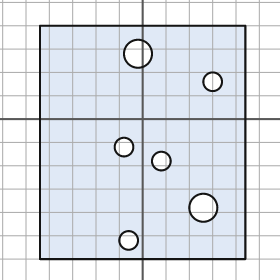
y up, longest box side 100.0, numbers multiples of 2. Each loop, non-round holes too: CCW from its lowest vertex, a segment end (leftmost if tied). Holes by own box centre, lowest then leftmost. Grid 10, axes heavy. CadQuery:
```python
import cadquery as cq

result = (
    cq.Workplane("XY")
    .moveTo(-44.0, -60.0)
    .lineTo(44.0, -60.0)
    .lineTo(44.0, 40.0)
    .lineTo(-44.0, 40.0)
    .close()
    .moveTo(-6.0, -52.0)
    .circle(4.0)
    .moveTo(26.0, -38.0)
    .circle(6.0)
    .moveTo(8.0, -18.0)
    .circle(4.0)
    .moveTo(-8.0, -12.0)
    .circle(4.0)
    .moveTo(30.0, 16.0)
    .circle(4.0)
    .moveTo(-2.0, 28.0)
    .circle(6.0)
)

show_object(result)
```